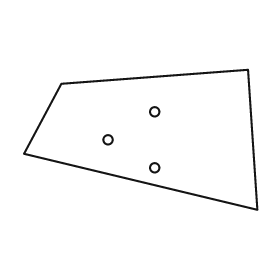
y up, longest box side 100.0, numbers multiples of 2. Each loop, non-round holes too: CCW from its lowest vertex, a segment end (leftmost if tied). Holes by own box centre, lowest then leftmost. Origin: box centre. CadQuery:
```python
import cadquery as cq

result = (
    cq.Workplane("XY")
    .moveTo(50.0, -30.0)
    .lineTo(46.0, 30.0)
    .lineTo(-34.0, 24.0)
    .lineTo(-50.0, -6.0)
    .close()
    .moveTo(6.0, -12.0)
    .circle(2.0)
    .moveTo(-14.0, 0.0)
    .circle(2.0)
    .moveTo(6.0, 12.0)
    .circle(2.0)
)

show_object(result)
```